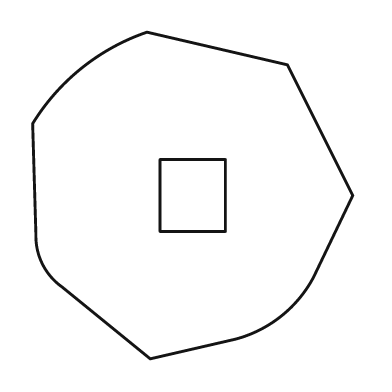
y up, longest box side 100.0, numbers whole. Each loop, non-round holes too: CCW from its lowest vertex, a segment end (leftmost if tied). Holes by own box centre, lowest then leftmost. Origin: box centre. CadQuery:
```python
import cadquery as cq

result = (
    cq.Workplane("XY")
    .moveTo(-13.0, -50.0)
    .lineTo(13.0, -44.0)
    .threePointArc((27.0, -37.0), (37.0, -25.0))
    .lineTo(49.0, 0.0)
    .lineTo(29.0, 40.0)
    .lineTo(-14.0, 50.0)
    .threePointArc((-34.0, 39.0), (-49.0, 22.0))
    .lineTo(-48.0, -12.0)
    .threePointArc((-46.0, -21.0), (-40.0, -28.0))
    .close()
    .moveTo(-10.0, -11.0)
    .lineTo(10.0, -11.0)
    .lineTo(10.0, 11.0)
    .lineTo(-10.0, 11.0)
    .close()
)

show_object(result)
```